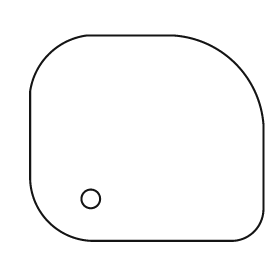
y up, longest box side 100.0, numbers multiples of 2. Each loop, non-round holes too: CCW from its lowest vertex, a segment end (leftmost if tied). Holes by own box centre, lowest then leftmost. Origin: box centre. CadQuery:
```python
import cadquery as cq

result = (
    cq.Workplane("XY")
    .moveTo(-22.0, -44.0)
    .lineTo(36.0, -44.0)
    .threePointArc((46.0, -40.0), (50.0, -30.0))
    .lineTo(50.0, 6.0)
    .threePointArc((38.0, 32.0), (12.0, 44.0))
    .lineTo(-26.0, 44.0)
    .threePointArc((-42.0, 36.0), (-50.0, 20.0))
    .lineTo(-50.0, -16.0)
    .threePointArc((-42.0, -36.0), (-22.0, -44.0))
    .close()
    .moveTo(-24.0, -26.0)
    .circle(4.0)
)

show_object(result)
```